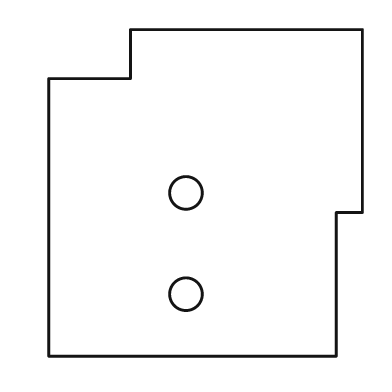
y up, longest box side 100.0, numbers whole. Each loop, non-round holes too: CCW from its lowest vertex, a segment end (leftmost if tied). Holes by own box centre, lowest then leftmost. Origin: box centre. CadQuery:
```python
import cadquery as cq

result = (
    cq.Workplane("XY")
    .moveTo(-48.0, -50.0)
    .lineTo(40.0, -50.0)
    .lineTo(40.0, -6.0)
    .lineTo(48.0, -6.0)
    .lineTo(48.0, 50.0)
    .lineTo(-23.0, 50.0)
    .lineTo(-23.0, 35.0)
    .lineTo(-48.0, 35.0)
    .close()
    .moveTo(-6.0, -31.0)
    .circle(5.0)
    .moveTo(-6.0, 0.0)
    .circle(5.0)
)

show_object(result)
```